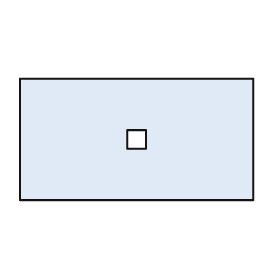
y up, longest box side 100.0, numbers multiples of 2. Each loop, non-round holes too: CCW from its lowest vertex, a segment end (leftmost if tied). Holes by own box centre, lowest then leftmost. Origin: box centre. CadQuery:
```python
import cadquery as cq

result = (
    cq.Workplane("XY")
    .moveTo(-50.0, -26.0)
    .lineTo(50.0, -26.0)
    .lineTo(50.0, 26.0)
    .lineTo(-50.0, 26.0)
    .close()
    .moveTo(-4.0, -4.0)
    .lineTo(4.0, -4.0)
    .lineTo(4.0, 4.0)
    .lineTo(-4.0, 4.0)
    .close()
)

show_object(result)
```